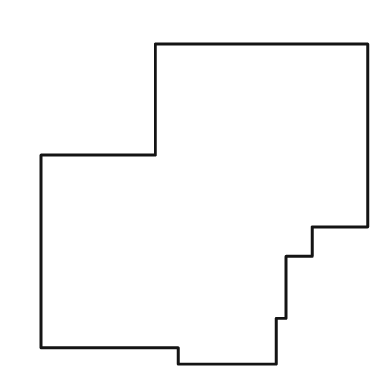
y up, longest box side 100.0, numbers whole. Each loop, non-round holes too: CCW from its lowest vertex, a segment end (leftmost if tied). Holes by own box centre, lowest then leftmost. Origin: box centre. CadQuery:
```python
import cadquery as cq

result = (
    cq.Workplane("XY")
    .moveTo(-8.0, -49.0)
    .lineTo(22.0, -49.0)
    .lineTo(22.0, -35.0)
    .lineTo(25.0, -35.0)
    .lineTo(25.0, -16.0)
    .lineTo(33.0, -16.0)
    .lineTo(33.0, -7.0)
    .lineTo(50.0, -7.0)
    .lineTo(50.0, 49.0)
    .lineTo(-15.0, 49.0)
    .lineTo(-15.0, 15.0)
    .lineTo(-50.0, 15.0)
    .lineTo(-50.0, -44.0)
    .lineTo(-8.0, -44.0)
    .close()
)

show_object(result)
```